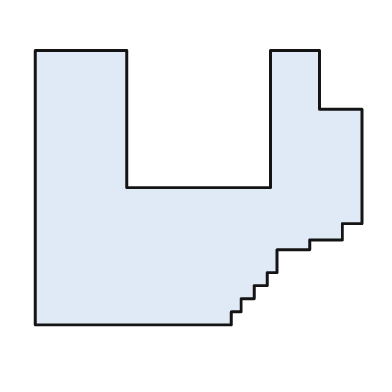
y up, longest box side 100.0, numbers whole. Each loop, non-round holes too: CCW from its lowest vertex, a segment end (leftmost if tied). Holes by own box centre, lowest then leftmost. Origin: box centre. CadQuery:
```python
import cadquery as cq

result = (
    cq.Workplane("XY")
    .moveTo(-50.0, -42.0)
    .lineTo(10.0, -42.0)
    .lineTo(10.0, -38.0)
    .lineTo(13.0, -38.0)
    .lineTo(13.0, -34.0)
    .lineTo(17.0, -34.0)
    .lineTo(17.0, -30.0)
    .lineTo(21.0, -30.0)
    .lineTo(21.0, -26.0)
    .lineTo(24.0, -26.0)
    .lineTo(24.0, -19.0)
    .lineTo(34.0, -19.0)
    .lineTo(34.0, -16.0)
    .lineTo(44.0, -16.0)
    .lineTo(44.0, -11.0)
    .lineTo(50.0, -11.0)
    .lineTo(50.0, 24.0)
    .lineTo(37.0, 24.0)
    .lineTo(37.0, 42.0)
    .lineTo(22.0, 42.0)
    .lineTo(22.0, 0.0)
    .lineTo(-22.0, 0.0)
    .lineTo(-22.0, 42.0)
    .lineTo(-50.0, 42.0)
    .close()
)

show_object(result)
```